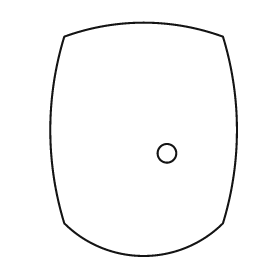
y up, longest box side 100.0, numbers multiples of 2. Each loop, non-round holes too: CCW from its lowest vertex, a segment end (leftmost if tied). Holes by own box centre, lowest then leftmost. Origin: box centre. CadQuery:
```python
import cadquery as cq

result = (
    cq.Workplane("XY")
    .moveTo(-34.0, -36.0)
    .threePointArc((0.0, -50.0), (34.0, -36.0))
    .threePointArc((40.0, 4.0), (34.0, 44.0))
    .threePointArc((0.0, 50.0), (-34.0, 44.0))
    .threePointArc((-40.0, 4.0), (-34.0, -36.0))
    .close()
    .moveTo(10.0, -6.0)
    .circle(4.0)
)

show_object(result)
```